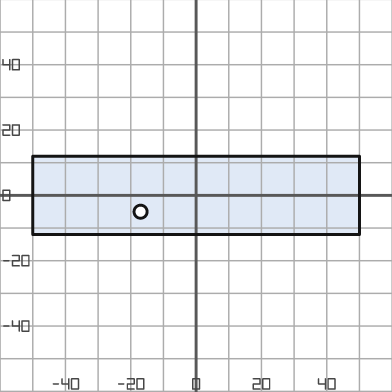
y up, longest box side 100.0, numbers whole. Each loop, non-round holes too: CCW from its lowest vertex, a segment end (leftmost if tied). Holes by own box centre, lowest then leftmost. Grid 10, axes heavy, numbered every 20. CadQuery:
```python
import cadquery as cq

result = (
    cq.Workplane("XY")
    .moveTo(-50.0, -12.0)
    .lineTo(50.0, -12.0)
    .lineTo(50.0, 12.0)
    .lineTo(-50.0, 12.0)
    .close()
    .moveTo(-17.0, -5.0)
    .circle(2.0)
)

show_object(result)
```